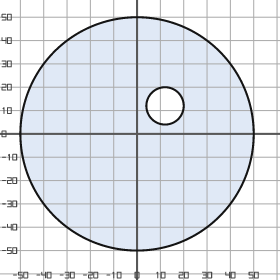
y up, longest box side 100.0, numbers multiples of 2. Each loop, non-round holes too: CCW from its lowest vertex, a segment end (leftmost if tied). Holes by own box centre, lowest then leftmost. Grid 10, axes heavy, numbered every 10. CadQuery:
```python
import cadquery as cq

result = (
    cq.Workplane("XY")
    .moveTo(0.0, 0.0)
    .circle(50.0)
    .moveTo(12.0, 12.0)
    .circle(8.0)
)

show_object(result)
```